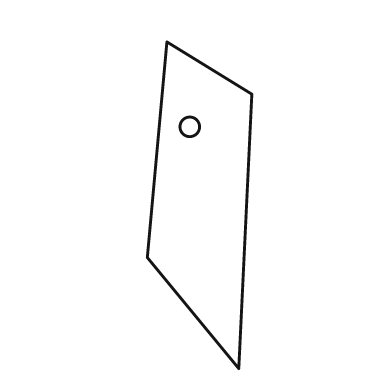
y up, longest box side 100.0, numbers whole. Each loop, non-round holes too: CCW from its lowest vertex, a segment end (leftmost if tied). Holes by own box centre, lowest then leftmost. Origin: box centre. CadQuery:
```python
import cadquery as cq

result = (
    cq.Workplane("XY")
    .moveTo(12.0, -50.0)
    .lineTo(16.0, 34.0)
    .lineTo(-10.0, 50.0)
    .lineTo(-16.0, -16.0)
    .close()
    .moveTo(-3.0, 24.0)
    .circle(3.0)
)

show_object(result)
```